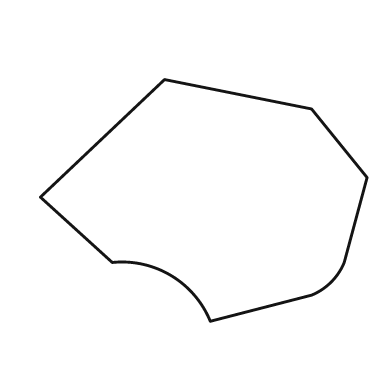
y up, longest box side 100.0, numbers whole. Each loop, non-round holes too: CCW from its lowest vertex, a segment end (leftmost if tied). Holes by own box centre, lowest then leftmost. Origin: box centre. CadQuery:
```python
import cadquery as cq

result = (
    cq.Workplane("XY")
    .moveTo(2.0, -37.0)
    .lineTo(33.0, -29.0)
    .threePointArc((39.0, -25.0), (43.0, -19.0))
    .lineTo(50.0, 7.0)
    .lineTo(33.0, 28.0)
    .lineTo(-12.0, 37.0)
    .lineTo(-50.0, 1.0)
    .lineTo(-28.0, -19.0)
    .threePointArc((-10.0, -23.0), (2.0, -37.0))
    .close()
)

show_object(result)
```